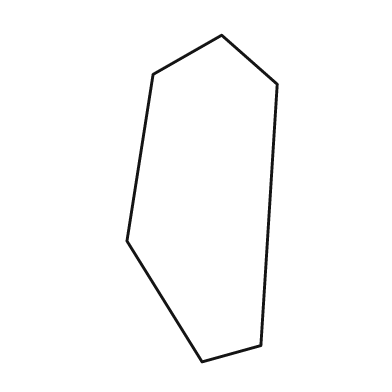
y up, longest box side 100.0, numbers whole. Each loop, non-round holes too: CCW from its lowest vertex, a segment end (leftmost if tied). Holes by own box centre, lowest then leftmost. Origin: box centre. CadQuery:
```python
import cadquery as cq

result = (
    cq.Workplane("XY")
    .moveTo(0.0, -50.0)
    .lineTo(18.0, -45.0)
    .lineTo(23.0, 35.0)
    .lineTo(6.0, 50.0)
    .lineTo(-15.0, 38.0)
    .lineTo(-23.0, -13.0)
    .close()
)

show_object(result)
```